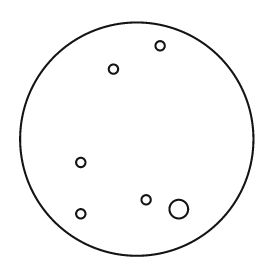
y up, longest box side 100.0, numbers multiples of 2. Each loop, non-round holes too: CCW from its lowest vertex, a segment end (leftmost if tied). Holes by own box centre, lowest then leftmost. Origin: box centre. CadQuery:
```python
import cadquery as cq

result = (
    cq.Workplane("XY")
    .moveTo(0.0, 0.0)
    .circle(50.0)
    .moveTo(-24.0, -32.0)
    .circle(2.0)
    .moveTo(18.0, -30.0)
    .circle(4.0)
    .moveTo(4.0, -26.0)
    .circle(2.0)
    .moveTo(-24.0, -10.0)
    .circle(2.0)
    .moveTo(-10.0, 30.0)
    .circle(2.0)
    .moveTo(10.0, 40.0)
    .circle(2.0)
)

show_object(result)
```